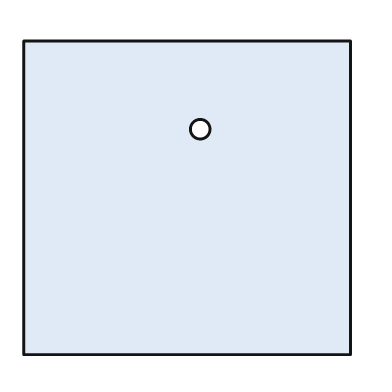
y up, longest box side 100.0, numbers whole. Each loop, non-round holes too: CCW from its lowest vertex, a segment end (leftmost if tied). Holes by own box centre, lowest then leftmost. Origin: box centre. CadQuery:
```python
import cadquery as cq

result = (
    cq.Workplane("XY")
    .moveTo(-50.0, -48.0)
    .lineTo(50.0, -48.0)
    .lineTo(50.0, 48.0)
    .lineTo(-50.0, 48.0)
    .close()
    .moveTo(4.0, 21.0)
    .circle(3.0)
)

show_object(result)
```